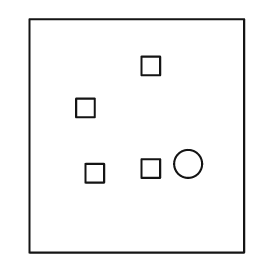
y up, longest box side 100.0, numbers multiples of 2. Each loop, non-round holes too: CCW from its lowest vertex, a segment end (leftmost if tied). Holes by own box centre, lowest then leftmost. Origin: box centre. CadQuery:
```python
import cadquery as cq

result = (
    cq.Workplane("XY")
    .moveTo(-46.0, -50.0)
    .lineTo(46.0, -50.0)
    .lineTo(46.0, 50.0)
    .lineTo(-46.0, 50.0)
    .close()
    .moveTo(-22.0, -20.0)
    .lineTo(-14.0, -20.0)
    .lineTo(-14.0, -12.0)
    .lineTo(-22.0, -12.0)
    .close()
    .moveTo(2.0, -18.0)
    .lineTo(10.0, -18.0)
    .lineTo(10.0, -10.0)
    .lineTo(2.0, -10.0)
    .close()
    .moveTo(22.0, -12.0)
    .circle(6.0)
    .moveTo(-26.0, 8.0)
    .lineTo(-18.0, 8.0)
    .lineTo(-18.0, 16.0)
    .lineTo(-26.0, 16.0)
    .close()
    .moveTo(2.0, 26.0)
    .lineTo(10.0, 26.0)
    .lineTo(10.0, 34.0)
    .lineTo(2.0, 34.0)
    .close()
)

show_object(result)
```